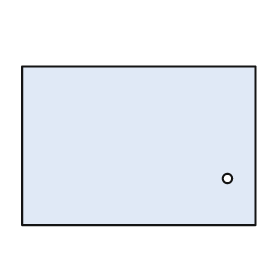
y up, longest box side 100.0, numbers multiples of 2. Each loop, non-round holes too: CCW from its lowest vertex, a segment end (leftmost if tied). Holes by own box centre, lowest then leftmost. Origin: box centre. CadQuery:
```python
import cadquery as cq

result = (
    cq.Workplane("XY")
    .moveTo(-50.0, -34.0)
    .lineTo(50.0, -34.0)
    .lineTo(50.0, 34.0)
    .lineTo(-50.0, 34.0)
    .close()
    .moveTo(38.0, -14.0)
    .circle(2.0)
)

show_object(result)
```